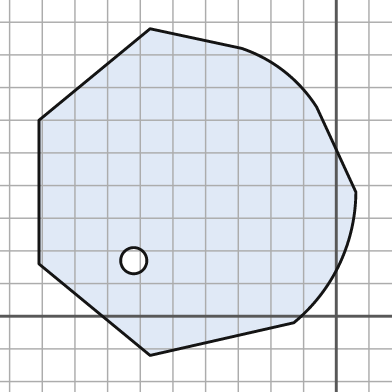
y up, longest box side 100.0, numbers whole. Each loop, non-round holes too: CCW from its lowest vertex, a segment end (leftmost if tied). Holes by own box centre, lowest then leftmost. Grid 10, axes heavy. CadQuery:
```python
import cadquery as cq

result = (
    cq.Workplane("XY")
    .moveTo(-57.0, -12.0)
    .lineTo(-13.0, -2.0)
    .threePointArc((1.0, 16.0), (6.0, 38.0))
    .lineTo(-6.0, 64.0)
    .threePointArc((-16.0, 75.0), (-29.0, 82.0))
    .lineTo(-57.0, 88.0)
    .lineTo(-91.0, 60.0)
    .lineTo(-91.0, 16.0)
    .close()
    .moveTo(-62.0, 17.0)
    .circle(4.0)
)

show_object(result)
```